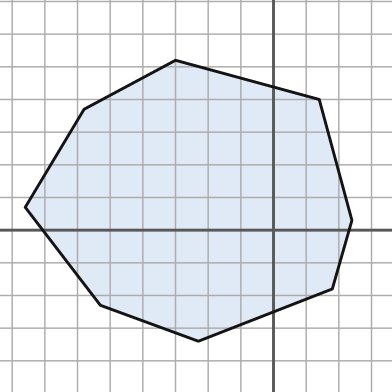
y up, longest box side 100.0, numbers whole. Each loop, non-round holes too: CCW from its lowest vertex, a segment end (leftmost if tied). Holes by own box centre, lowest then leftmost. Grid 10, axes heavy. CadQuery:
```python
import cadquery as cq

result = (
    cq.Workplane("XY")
    .moveTo(-23.0, -34.0)
    .lineTo(18.0, -18.0)
    .lineTo(24.0, 3.0)
    .lineTo(14.0, 40.0)
    .lineTo(-30.0, 52.0)
    .lineTo(-58.0, 37.0)
    .lineTo(-76.0, 7.0)
    .lineTo(-53.0, -23.0)
    .close()
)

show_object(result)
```